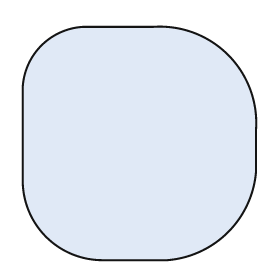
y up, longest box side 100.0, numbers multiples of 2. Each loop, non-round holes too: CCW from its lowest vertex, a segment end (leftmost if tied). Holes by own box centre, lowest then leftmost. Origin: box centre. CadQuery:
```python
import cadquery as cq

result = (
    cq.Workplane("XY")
    .moveTo(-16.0, -50.0)
    .lineTo(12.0, -50.0)
    .threePointArc((38.0, -38.0), (50.0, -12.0))
    .lineTo(50.0, 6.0)
    .threePointArc((38.0, 38.0), (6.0, 50.0))
    .lineTo(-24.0, 50.0)
    .threePointArc((-42.0, 42.0), (-50.0, 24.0))
    .lineTo(-50.0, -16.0)
    .threePointArc((-40.0, -40.0), (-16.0, -50.0))
    .close()
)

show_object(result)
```